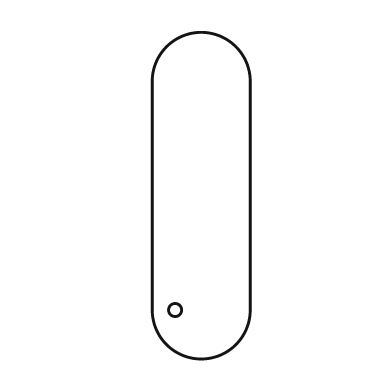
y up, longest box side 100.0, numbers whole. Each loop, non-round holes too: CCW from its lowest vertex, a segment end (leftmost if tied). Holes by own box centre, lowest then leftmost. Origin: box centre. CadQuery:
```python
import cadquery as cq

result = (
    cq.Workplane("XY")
    .moveTo(-15.0, -35.0)
    .threePointArc((0.0, -50.0), (15.0, -35.0))
    .lineTo(15.0, 35.0)
    .threePointArc((0.0, 50.0), (-15.0, 35.0))
    .close()
    .moveTo(-8.0, -35.0)
    .circle(2.0)
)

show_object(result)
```